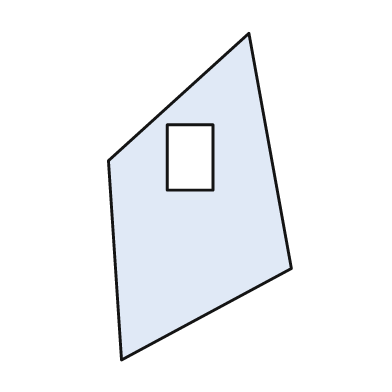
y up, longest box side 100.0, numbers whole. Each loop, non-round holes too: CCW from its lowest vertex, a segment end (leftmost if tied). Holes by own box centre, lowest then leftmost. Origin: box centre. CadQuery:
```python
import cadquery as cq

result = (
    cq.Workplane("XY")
    .moveTo(-24.0, -50.0)
    .lineTo(28.0, -22.0)
    .lineTo(15.0, 50.0)
    .lineTo(-28.0, 11.0)
    .close()
    .moveTo(-10.0, 2.0)
    .lineTo(4.0, 2.0)
    .lineTo(4.0, 22.0)
    .lineTo(-10.0, 22.0)
    .close()
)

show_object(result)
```